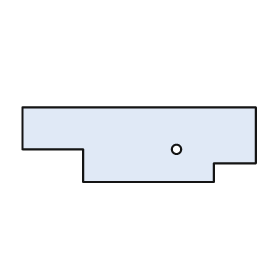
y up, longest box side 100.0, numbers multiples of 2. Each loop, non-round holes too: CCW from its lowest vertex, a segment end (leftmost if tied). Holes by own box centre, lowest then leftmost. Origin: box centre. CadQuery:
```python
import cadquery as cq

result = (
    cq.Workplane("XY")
    .moveTo(-24.0, -16.0)
    .lineTo(32.0, -16.0)
    .lineTo(32.0, -8.0)
    .lineTo(50.0, -8.0)
    .lineTo(50.0, 16.0)
    .lineTo(-50.0, 16.0)
    .lineTo(-50.0, -2.0)
    .lineTo(-24.0, -2.0)
    .close()
    .moveTo(16.0, -2.0)
    .circle(2.0)
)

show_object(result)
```